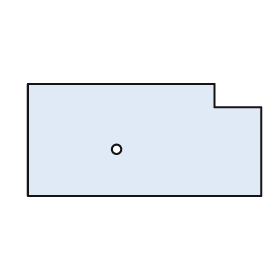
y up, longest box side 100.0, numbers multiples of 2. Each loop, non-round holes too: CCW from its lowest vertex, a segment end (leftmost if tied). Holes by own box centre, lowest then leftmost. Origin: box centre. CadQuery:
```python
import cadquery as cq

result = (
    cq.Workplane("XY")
    .moveTo(-50.0, -24.0)
    .lineTo(50.0, -24.0)
    .lineTo(50.0, 14.0)
    .lineTo(30.0, 14.0)
    .lineTo(30.0, 24.0)
    .lineTo(-50.0, 24.0)
    .close()
    .moveTo(-12.0, -4.0)
    .circle(2.0)
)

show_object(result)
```